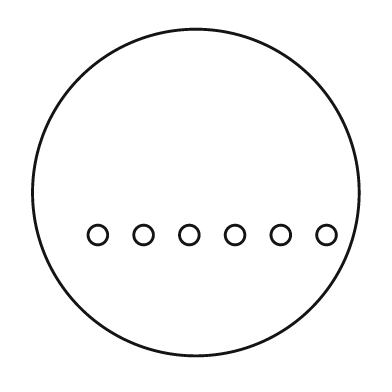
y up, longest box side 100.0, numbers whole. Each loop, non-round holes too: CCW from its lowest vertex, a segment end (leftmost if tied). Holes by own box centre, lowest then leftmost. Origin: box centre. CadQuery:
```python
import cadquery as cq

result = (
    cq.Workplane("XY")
    .moveTo(0.0, 0.0)
    .circle(50.0)
    .moveTo(-30.0, -13.0)
    .circle(3.0)
    .moveTo(-16.0, -13.0)
    .circle(3.0)
    .moveTo(-2.0, -13.0)
    .circle(3.0)
    .moveTo(12.0, -13.0)
    .circle(3.0)
    .moveTo(26.0, -13.0)
    .circle(3.0)
    .moveTo(40.0, -13.0)
    .circle(3.0)
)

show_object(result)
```